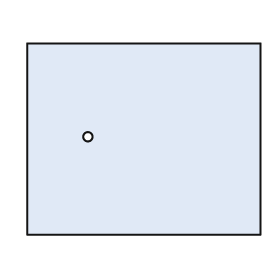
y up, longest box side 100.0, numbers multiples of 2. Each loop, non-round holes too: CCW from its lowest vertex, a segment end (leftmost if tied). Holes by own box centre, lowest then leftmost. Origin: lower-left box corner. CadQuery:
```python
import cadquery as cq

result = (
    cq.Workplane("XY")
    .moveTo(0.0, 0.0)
    .lineTo(100.0, 0.0)
    .lineTo(100.0, 82.0)
    .lineTo(0.0, 82.0)
    .close()
    .moveTo(26.0, 42.0)
    .circle(2.0)
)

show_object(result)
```